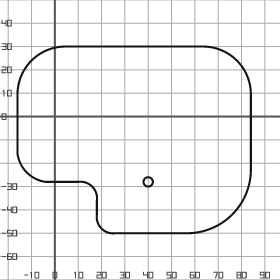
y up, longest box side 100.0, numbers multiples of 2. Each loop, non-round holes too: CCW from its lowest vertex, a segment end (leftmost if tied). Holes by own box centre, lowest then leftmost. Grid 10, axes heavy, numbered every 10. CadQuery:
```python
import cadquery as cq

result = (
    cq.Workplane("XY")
    .moveTo(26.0, -50.0)
    .lineTo(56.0, -50.0)
    .threePointArc((76.0, -42.0), (84.0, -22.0))
    .lineTo(84.0, 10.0)
    .threePointArc((78.0, 24.0), (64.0, 30.0))
    .lineTo(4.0, 30.0)
    .threePointArc((-10.0, 24.0), (-16.0, 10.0))
    .lineTo(-16.0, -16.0)
    .threePointArc((-12.0, -24.0), (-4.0, -28.0))
    .lineTo(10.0, -28.0)
    .threePointArc((16.0, -30.0), (18.0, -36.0))
    .lineTo(18.0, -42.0)
    .threePointArc((20.0, -48.0), (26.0, -50.0))
    .close()
    .moveTo(40.0, -28.0)
    .circle(2.0)
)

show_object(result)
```